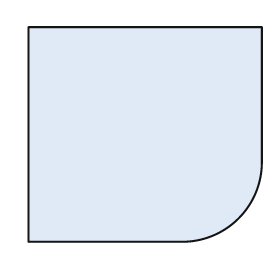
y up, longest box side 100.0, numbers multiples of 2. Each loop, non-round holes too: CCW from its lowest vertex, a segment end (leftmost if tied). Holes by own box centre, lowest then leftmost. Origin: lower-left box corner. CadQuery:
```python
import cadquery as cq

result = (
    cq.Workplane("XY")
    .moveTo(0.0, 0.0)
    .lineTo(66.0, 0.0)
    .threePointArc((90.0, 10.0), (100.0, 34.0))
    .lineTo(100.0, 92.0)
    .lineTo(0.0, 92.0)
    .close()
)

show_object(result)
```